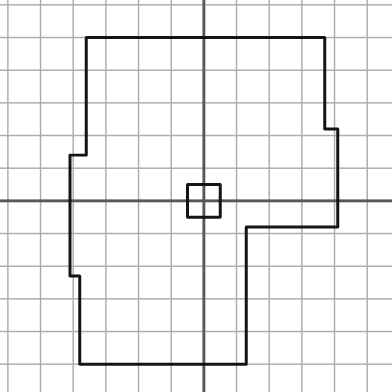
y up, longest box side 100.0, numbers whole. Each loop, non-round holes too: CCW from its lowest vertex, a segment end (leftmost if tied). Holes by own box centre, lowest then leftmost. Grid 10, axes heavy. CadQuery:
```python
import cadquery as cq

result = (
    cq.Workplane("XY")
    .moveTo(-38.0, -50.0)
    .lineTo(13.0, -50.0)
    .lineTo(13.0, -8.0)
    .lineTo(41.0, -8.0)
    .lineTo(41.0, 22.0)
    .lineTo(37.0, 22.0)
    .lineTo(37.0, 50.0)
    .lineTo(-36.0, 50.0)
    .lineTo(-36.0, 14.0)
    .lineTo(-41.0, 14.0)
    .lineTo(-41.0, -23.0)
    .lineTo(-38.0, -23.0)
    .close()
    .moveTo(-5.0, -5.0)
    .lineTo(5.0, -5.0)
    .lineTo(5.0, 5.0)
    .lineTo(-5.0, 5.0)
    .close()
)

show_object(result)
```